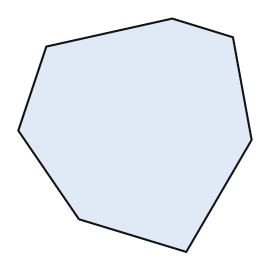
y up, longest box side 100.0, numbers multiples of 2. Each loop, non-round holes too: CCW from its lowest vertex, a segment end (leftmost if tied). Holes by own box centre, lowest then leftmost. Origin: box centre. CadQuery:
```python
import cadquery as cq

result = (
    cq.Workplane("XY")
    .moveTo(22.0, -50.0)
    .lineTo(50.0, -2.0)
    .lineTo(42.0, 42.0)
    .lineTo(16.0, 50.0)
    .lineTo(-38.0, 38.0)
    .lineTo(-50.0, 2.0)
    .lineTo(-24.0, -36.0)
    .close()
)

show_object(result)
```